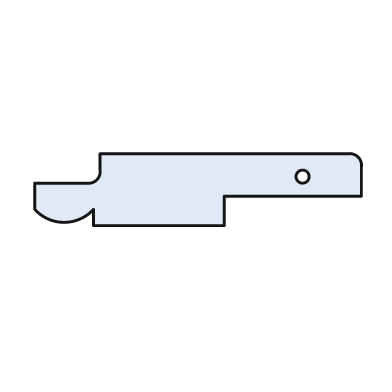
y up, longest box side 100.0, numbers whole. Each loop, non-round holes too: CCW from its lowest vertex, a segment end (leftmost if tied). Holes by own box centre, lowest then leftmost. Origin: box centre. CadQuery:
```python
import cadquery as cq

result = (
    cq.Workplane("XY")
    .moveTo(-32.0, -11.0)
    .lineTo(8.0, -11.0)
    .lineTo(8.0, -2.0)
    .lineTo(50.0, -2.0)
    .lineTo(50.0, 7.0)
    .threePointArc((49.0, 10.0), (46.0, 11.0))
    .lineTo(-30.0, 11.0)
    .lineTo(-30.0, 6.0)
    .threePointArc((-31.0, 3.0), (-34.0, 2.0))
    .lineTo(-50.0, 2.0)
    .lineTo(-50.0, -6.0)
    .threePointArc((-41.0, -10.0), (-32.0, -6.0))
    .close()
    .moveTo(32.0, 4.0)
    .circle(2.0)
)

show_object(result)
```